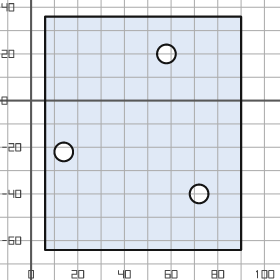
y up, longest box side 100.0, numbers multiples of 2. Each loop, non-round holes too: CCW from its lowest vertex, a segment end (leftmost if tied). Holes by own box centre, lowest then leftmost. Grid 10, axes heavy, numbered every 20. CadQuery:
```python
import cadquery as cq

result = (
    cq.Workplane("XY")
    .moveTo(6.0, -64.0)
    .lineTo(90.0, -64.0)
    .lineTo(90.0, 36.0)
    .lineTo(6.0, 36.0)
    .close()
    .moveTo(72.0, -40.0)
    .circle(4.0)
    .moveTo(14.0, -22.0)
    .circle(4.0)
    .moveTo(58.0, 20.0)
    .circle(4.0)
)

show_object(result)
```